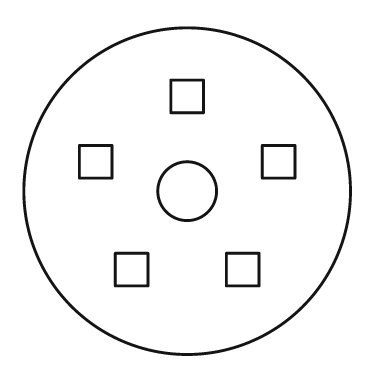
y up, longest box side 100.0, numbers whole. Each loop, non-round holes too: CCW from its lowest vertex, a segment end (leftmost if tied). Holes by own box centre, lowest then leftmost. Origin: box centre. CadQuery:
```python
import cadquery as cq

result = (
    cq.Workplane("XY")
    .moveTo(0.0, 0.0)
    .circle(50.0)
    .moveTo(-22.0, -29.0)
    .lineTo(-12.0, -29.0)
    .lineTo(-12.0, -19.0)
    .lineTo(-22.0, -19.0)
    .close()
    .moveTo(12.0, -29.0)
    .lineTo(22.0, -29.0)
    .lineTo(22.0, -19.0)
    .lineTo(12.0, -19.0)
    .close()
    .moveTo(0.0, 0.0)
    .circle(9.0)
    .moveTo(-33.0, 4.0)
    .lineTo(-23.0, 4.0)
    .lineTo(-23.0, 14.0)
    .lineTo(-33.0, 14.0)
    .close()
    .moveTo(23.0, 4.0)
    .lineTo(33.0, 4.0)
    .lineTo(33.0, 14.0)
    .lineTo(23.0, 14.0)
    .close()
    .moveTo(-5.0, 24.0)
    .lineTo(5.0, 24.0)
    .lineTo(5.0, 34.0)
    .lineTo(-5.0, 34.0)
    .close()
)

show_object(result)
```